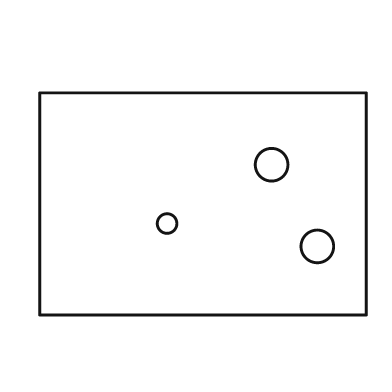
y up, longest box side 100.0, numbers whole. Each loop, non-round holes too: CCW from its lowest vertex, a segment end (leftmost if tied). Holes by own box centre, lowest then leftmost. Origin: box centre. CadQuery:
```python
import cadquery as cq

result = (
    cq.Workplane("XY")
    .moveTo(-50.0, -34.0)
    .lineTo(50.0, -34.0)
    .lineTo(50.0, 34.0)
    .lineTo(-50.0, 34.0)
    .close()
    .moveTo(35.0, -13.0)
    .circle(5.0)
    .moveTo(-11.0, -6.0)
    .circle(3.0)
    .moveTo(21.0, 12.0)
    .circle(5.0)
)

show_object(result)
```